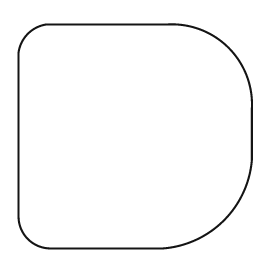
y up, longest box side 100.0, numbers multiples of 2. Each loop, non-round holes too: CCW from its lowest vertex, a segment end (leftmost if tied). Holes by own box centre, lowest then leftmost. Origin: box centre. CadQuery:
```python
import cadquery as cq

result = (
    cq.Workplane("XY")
    .moveTo(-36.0, -48.0)
    .lineTo(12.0, -48.0)
    .threePointArc((38.0, -36.0), (50.0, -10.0))
    .lineTo(50.0, 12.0)
    .threePointArc((40.0, 38.0), (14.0, 48.0))
    .lineTo(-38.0, 48.0)
    .threePointArc((-46.0, 44.0), (-50.0, 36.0))
    .lineTo(-50.0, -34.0)
    .threePointArc((-46.0, -44.0), (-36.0, -48.0))
    .close()
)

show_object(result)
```